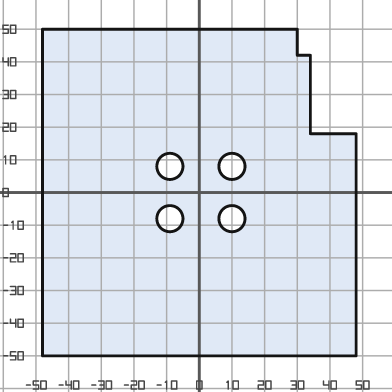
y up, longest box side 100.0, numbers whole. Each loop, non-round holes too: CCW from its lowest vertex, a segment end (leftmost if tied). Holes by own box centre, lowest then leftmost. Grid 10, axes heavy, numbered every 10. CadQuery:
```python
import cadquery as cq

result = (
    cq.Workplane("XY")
    .moveTo(-48.0, -50.0)
    .lineTo(48.0, -50.0)
    .lineTo(48.0, 18.0)
    .lineTo(34.0, 18.0)
    .lineTo(34.0, 42.0)
    .lineTo(30.0, 42.0)
    .lineTo(30.0, 50.0)
    .lineTo(-48.0, 50.0)
    .close()
    .moveTo(-9.0, -8.0)
    .circle(4.0)
    .moveTo(10.0, -8.0)
    .circle(4.0)
    .moveTo(-9.0, 8.0)
    .circle(4.0)
    .moveTo(10.0, 8.0)
    .circle(4.0)
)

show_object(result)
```